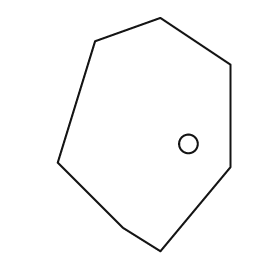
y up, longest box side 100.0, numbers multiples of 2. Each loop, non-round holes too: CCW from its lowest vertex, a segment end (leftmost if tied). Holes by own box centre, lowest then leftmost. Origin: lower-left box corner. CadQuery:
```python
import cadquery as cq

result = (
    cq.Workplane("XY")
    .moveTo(44.0, 0.0)
    .lineTo(74.0, 36.0)
    .lineTo(74.0, 80.0)
    .lineTo(44.0, 100.0)
    .lineTo(16.0, 90.0)
    .lineTo(0.0, 38.0)
    .lineTo(28.0, 10.0)
    .close()
    .moveTo(56.0, 46.0)
    .circle(4.0)
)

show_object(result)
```